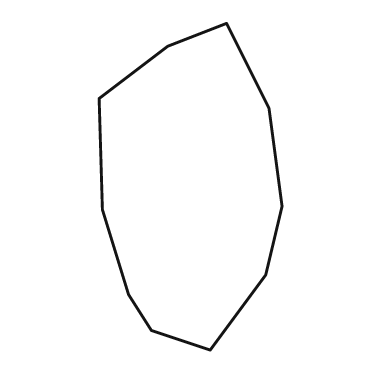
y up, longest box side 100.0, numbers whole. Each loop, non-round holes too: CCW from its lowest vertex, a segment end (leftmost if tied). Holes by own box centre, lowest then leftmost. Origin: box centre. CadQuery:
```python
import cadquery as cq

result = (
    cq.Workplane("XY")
    .moveTo(6.0, -50.0)
    .lineTo(23.0, -27.0)
    .lineTo(28.0, -6.0)
    .lineTo(24.0, 24.0)
    .lineTo(11.0, 50.0)
    .lineTo(-7.0, 43.0)
    .lineTo(-28.0, 27.0)
    .lineTo(-27.0, -7.0)
    .lineTo(-19.0, -33.0)
    .lineTo(-12.0, -44.0)
    .close()
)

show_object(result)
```